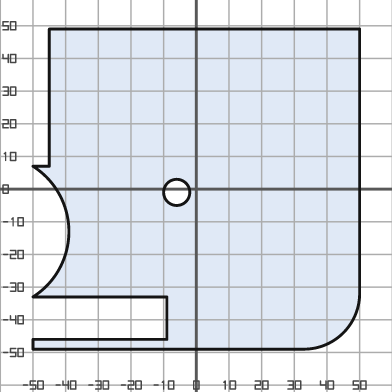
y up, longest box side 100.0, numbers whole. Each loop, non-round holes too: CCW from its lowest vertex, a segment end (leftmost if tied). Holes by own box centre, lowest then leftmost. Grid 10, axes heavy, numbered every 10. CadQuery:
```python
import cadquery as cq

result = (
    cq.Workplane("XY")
    .moveTo(-50.0, -49.0)
    .lineTo(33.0, -49.0)
    .threePointArc((45.0, -44.0), (50.0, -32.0))
    .lineTo(50.0, 49.0)
    .lineTo(-45.0, 49.0)
    .lineTo(-45.0, 7.0)
    .lineTo(-50.0, 7.0)
    .threePointArc((-39.0, -13.0), (-50.0, -33.0))
    .lineTo(-9.0, -33.0)
    .lineTo(-9.0, -46.0)
    .lineTo(-50.0, -46.0)
    .close()
    .moveTo(-6.0, -1.0)
    .circle(4.0)
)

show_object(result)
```